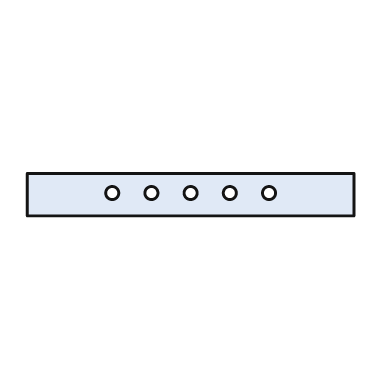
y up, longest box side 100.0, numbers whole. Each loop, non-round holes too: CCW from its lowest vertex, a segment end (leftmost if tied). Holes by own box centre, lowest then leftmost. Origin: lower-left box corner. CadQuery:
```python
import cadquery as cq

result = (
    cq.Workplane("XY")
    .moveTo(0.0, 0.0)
    .lineTo(100.0, 0.0)
    .lineTo(100.0, 13.0)
    .lineTo(0.0, 13.0)
    .close()
    .moveTo(26.0, 7.0)
    .circle(2.0)
    .moveTo(38.0, 7.0)
    .circle(2.0)
    .moveTo(50.0, 7.0)
    .circle(2.0)
    .moveTo(62.0, 7.0)
    .circle(2.0)
    .moveTo(74.0, 7.0)
    .circle(2.0)
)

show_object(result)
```